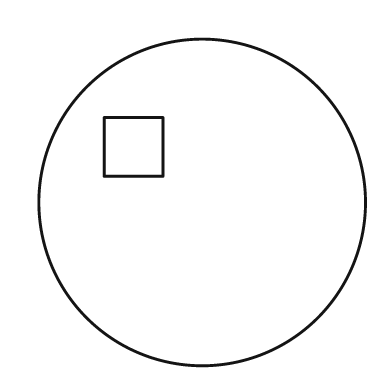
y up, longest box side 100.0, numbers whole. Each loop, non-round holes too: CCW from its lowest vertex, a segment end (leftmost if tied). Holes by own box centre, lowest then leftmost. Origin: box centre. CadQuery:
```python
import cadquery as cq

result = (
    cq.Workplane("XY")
    .moveTo(0.0, 0.0)
    .circle(50.0)
    .moveTo(-30.0, 8.0)
    .lineTo(-12.0, 8.0)
    .lineTo(-12.0, 26.0)
    .lineTo(-30.0, 26.0)
    .close()
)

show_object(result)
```